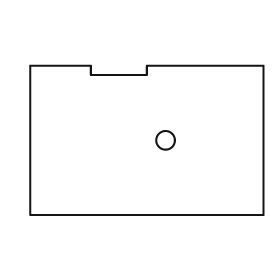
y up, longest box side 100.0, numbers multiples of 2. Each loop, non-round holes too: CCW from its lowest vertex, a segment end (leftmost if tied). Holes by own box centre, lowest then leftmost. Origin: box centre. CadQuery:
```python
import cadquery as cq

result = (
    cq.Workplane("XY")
    .moveTo(-50.0, -32.0)
    .lineTo(50.0, -32.0)
    .lineTo(50.0, 32.0)
    .lineTo(0.0, 32.0)
    .lineTo(0.0, 28.0)
    .lineTo(-24.0, 28.0)
    .lineTo(-24.0, 32.0)
    .lineTo(-50.0, 32.0)
    .close()
    .moveTo(8.0, 0.0)
    .circle(4.0)
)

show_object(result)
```